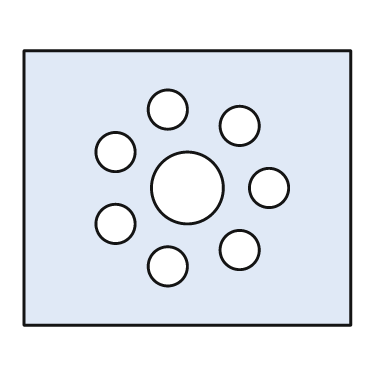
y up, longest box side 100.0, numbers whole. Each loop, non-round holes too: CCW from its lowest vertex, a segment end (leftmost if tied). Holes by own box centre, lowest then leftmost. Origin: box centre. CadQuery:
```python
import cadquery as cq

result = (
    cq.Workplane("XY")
    .moveTo(-50.0, -42.0)
    .lineTo(50.0, -42.0)
    .lineTo(50.0, 42.0)
    .lineTo(-50.0, 42.0)
    .close()
    .moveTo(-6.0, -24.0)
    .circle(6.0)
    .moveTo(16.0, -19.0)
    .circle(6.0)
    .moveTo(-22.0, -11.0)
    .circle(6.0)
    .moveTo(0.0, 0.0)
    .circle(11.0)
    .moveTo(25.0, 0.0)
    .circle(6.0)
    .moveTo(-22.0, 11.0)
    .circle(6.0)
    .moveTo(16.0, 19.0)
    .circle(6.0)
    .moveTo(-6.0, 24.0)
    .circle(6.0)
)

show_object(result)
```